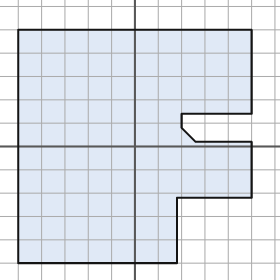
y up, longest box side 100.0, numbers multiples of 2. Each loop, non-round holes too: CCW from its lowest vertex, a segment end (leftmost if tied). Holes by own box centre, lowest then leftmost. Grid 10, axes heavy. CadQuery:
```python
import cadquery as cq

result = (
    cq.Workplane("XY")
    .moveTo(-50.0, -50.0)
    .lineTo(18.0, -50.0)
    .lineTo(18.0, -22.0)
    .lineTo(50.0, -22.0)
    .lineTo(50.0, 2.0)
    .lineTo(26.0, 2.0)
    .lineTo(20.0, 8.0)
    .lineTo(20.0, 14.0)
    .lineTo(50.0, 14.0)
    .lineTo(50.0, 50.0)
    .lineTo(-50.0, 50.0)
    .close()
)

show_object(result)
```